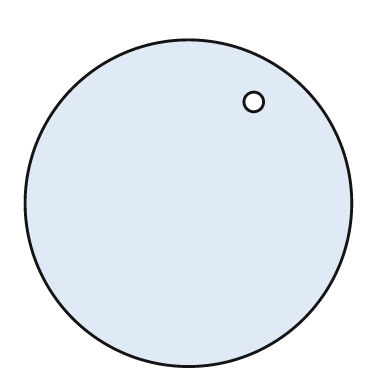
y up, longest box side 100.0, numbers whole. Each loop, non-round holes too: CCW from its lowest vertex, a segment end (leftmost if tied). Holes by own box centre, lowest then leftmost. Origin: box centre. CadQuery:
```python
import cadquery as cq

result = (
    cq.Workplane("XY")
    .moveTo(0.0, 0.0)
    .circle(50.0)
    .moveTo(20.0, 31.0)
    .circle(3.0)
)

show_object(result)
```